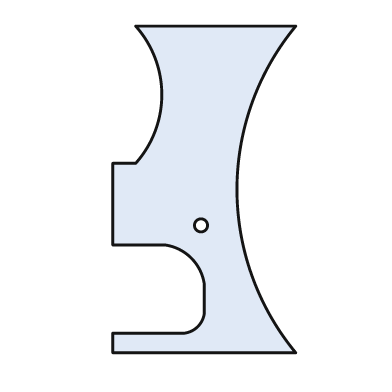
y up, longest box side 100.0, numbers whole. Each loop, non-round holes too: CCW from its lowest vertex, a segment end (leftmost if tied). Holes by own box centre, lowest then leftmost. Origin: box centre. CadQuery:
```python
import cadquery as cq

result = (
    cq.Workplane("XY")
    .moveTo(-28.0, -50.0)
    .lineTo(28.0, -50.0)
    .threePointArc((10.0, 0.0), (28.0, 50.0))
    .lineTo(-21.0, 50.0)
    .threePointArc((-13.0, 29.0), (-21.0, 8.0))
    .lineTo(-28.0, 8.0)
    .lineTo(-28.0, -17.0)
    .lineTo(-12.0, -17.0)
    .threePointArc((-4.0, -21.0), (0.0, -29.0))
    .lineTo(0.0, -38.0)
    .threePointArc((-2.0, -42.0), (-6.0, -44.0))
    .lineTo(-28.0, -44.0)
    .close()
    .moveTo(-1.0, -11.0)
    .circle(2.0)
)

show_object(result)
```